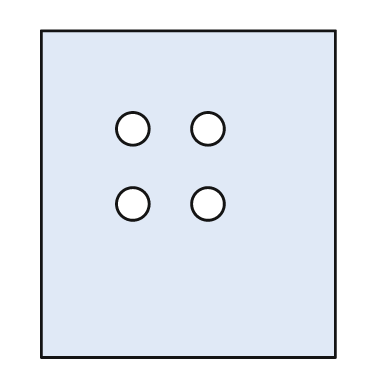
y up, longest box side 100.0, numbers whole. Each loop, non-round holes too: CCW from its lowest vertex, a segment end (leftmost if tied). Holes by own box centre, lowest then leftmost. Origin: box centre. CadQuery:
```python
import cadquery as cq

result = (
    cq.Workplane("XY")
    .moveTo(-45.0, -50.0)
    .lineTo(45.0, -50.0)
    .lineTo(45.0, 50.0)
    .lineTo(-45.0, 50.0)
    .close()
    .moveTo(-17.0, -3.0)
    .circle(5.0)
    .moveTo(6.0, -3.0)
    .circle(5.0)
    .moveTo(-17.0, 20.0)
    .circle(5.0)
    .moveTo(6.0, 20.0)
    .circle(5.0)
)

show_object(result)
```